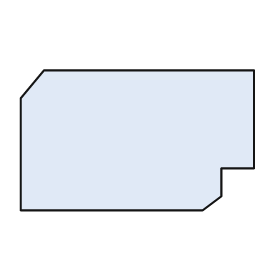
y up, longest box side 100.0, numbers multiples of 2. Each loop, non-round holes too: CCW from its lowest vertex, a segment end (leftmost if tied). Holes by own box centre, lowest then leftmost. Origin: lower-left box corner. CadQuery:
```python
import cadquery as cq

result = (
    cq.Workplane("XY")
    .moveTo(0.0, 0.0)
    .lineTo(78.0, 0.0)
    .lineTo(86.0, 6.0)
    .lineTo(86.0, 18.0)
    .lineTo(100.0, 18.0)
    .lineTo(100.0, 60.0)
    .lineTo(10.0, 60.0)
    .lineTo(0.0, 48.0)
    .close()
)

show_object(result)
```